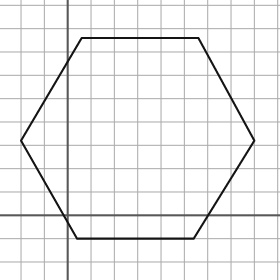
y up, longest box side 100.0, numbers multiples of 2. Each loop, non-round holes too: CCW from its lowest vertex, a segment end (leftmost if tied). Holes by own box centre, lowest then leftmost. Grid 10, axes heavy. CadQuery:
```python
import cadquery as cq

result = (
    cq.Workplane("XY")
    .moveTo(4.0, -10.0)
    .lineTo(54.0, -10.0)
    .lineTo(80.0, 32.0)
    .lineTo(56.0, 76.0)
    .lineTo(6.0, 76.0)
    .lineTo(-20.0, 32.0)
    .close()
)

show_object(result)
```